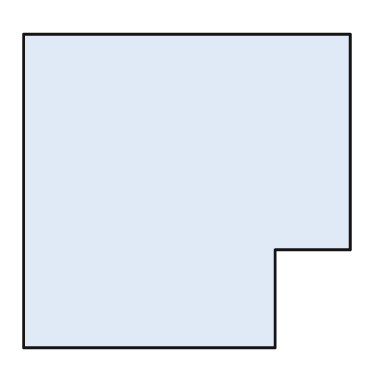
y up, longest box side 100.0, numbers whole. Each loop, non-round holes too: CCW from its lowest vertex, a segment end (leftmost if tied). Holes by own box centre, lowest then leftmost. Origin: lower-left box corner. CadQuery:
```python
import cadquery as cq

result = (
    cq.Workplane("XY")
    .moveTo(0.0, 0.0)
    .lineTo(77.0, 0.0)
    .lineTo(77.0, 30.0)
    .lineTo(100.0, 30.0)
    .lineTo(100.0, 96.0)
    .lineTo(0.0, 96.0)
    .close()
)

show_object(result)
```